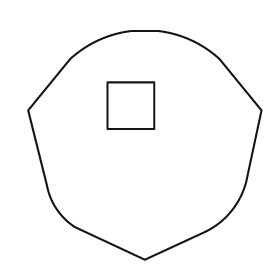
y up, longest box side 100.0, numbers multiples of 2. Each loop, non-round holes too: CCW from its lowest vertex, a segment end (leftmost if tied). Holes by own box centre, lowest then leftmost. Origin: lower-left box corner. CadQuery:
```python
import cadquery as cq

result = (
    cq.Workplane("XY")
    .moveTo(50.0, 0.0)
    .lineTo(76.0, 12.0)
    .threePointArc((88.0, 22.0), (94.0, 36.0))
    .lineTo(100.0, 64.0)
    .lineTo(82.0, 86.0)
    .threePointArc((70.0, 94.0), (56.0, 98.0))
    .lineTo(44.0, 98.0)
    .threePointArc((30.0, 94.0), (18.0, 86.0))
    .lineTo(0.0, 64.0)
    .lineTo(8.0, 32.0)
    .threePointArc((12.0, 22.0), (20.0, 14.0))
    .close()
    .moveTo(34.0, 56.0)
    .lineTo(54.0, 56.0)
    .lineTo(54.0, 76.0)
    .lineTo(34.0, 76.0)
    .close()
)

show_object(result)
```